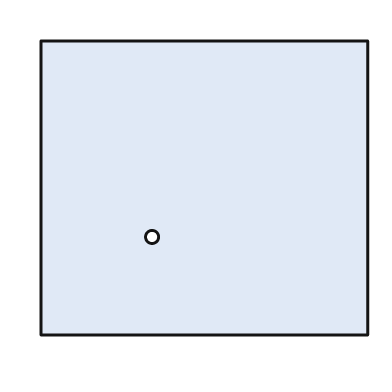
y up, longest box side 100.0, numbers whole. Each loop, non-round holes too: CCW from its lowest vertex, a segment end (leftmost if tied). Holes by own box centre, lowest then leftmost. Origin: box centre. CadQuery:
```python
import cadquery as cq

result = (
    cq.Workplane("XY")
    .moveTo(-50.0, -45.0)
    .lineTo(50.0, -45.0)
    .lineTo(50.0, 45.0)
    .lineTo(-50.0, 45.0)
    .close()
    .moveTo(-16.0, -15.0)
    .circle(2.0)
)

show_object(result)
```